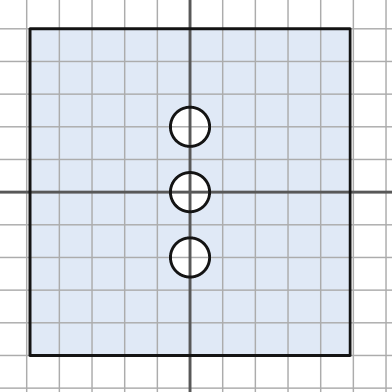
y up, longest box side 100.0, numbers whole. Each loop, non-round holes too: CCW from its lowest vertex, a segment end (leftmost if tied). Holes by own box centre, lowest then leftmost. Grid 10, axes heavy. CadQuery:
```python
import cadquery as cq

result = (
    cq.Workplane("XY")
    .moveTo(-49.0, -50.0)
    .lineTo(49.0, -50.0)
    .lineTo(49.0, 50.0)
    .lineTo(-49.0, 50.0)
    .close()
    .moveTo(0.0, -20.0)
    .circle(6.0)
    .moveTo(0.0, 0.0)
    .circle(6.0)
    .moveTo(0.0, 20.0)
    .circle(6.0)
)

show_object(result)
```